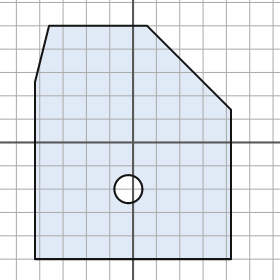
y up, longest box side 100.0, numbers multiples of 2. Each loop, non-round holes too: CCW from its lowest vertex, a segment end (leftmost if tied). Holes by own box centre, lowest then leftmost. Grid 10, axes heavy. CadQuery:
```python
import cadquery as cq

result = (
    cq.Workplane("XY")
    .moveTo(-42.0, -50.0)
    .lineTo(42.0, -50.0)
    .lineTo(42.0, 14.0)
    .lineTo(6.0, 50.0)
    .lineTo(-36.0, 50.0)
    .lineTo(-42.0, 26.0)
    .close()
    .moveTo(-2.0, -20.0)
    .circle(6.0)
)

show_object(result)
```